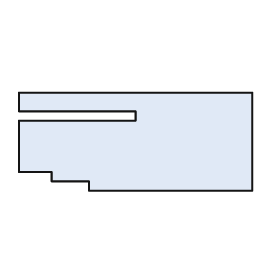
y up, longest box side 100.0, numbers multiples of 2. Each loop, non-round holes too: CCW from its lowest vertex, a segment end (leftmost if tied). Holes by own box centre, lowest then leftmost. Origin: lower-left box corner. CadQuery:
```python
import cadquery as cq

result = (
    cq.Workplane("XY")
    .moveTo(30.0, 0.0)
    .lineTo(100.0, 0.0)
    .lineTo(100.0, 42.0)
    .lineTo(0.0, 42.0)
    .lineTo(0.0, 34.0)
    .lineTo(50.0, 34.0)
    .lineTo(50.0, 30.0)
    .lineTo(0.0, 30.0)
    .lineTo(0.0, 8.0)
    .lineTo(14.0, 8.0)
    .lineTo(14.0, 4.0)
    .lineTo(30.0, 4.0)
    .close()
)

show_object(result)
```